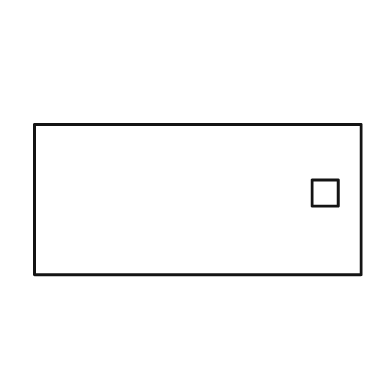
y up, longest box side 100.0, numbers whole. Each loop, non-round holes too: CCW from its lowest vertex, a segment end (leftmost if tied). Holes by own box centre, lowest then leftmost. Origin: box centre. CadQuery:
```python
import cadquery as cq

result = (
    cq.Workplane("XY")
    .moveTo(-50.0, -23.0)
    .lineTo(50.0, -23.0)
    .lineTo(50.0, 23.0)
    .lineTo(-50.0, 23.0)
    .close()
    .moveTo(35.0, -2.0)
    .lineTo(43.0, -2.0)
    .lineTo(43.0, 6.0)
    .lineTo(35.0, 6.0)
    .close()
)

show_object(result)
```